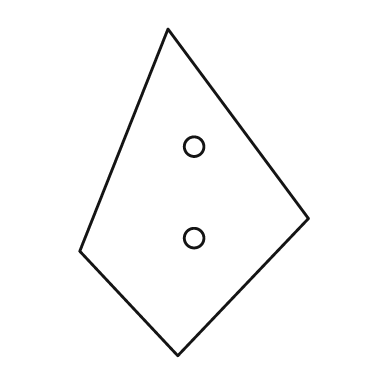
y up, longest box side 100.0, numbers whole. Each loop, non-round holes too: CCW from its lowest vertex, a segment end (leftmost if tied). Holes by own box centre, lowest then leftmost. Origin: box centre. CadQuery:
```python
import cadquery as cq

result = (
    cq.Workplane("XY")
    .moveTo(-5.0, -50.0)
    .lineTo(35.0, -8.0)
    .lineTo(-8.0, 50.0)
    .lineTo(-35.0, -18.0)
    .close()
    .moveTo(0.0, -14.0)
    .circle(3.0)
    .moveTo(0.0, 14.0)
    .circle(3.0)
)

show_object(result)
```